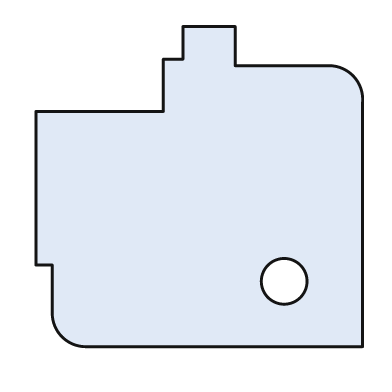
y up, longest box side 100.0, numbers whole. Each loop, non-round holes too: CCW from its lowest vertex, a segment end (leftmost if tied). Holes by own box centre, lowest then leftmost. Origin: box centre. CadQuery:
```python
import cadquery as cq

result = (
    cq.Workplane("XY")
    .moveTo(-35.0, -49.0)
    .lineTo(50.0, -49.0)
    .lineTo(50.0, 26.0)
    .threePointArc((47.0, 34.0), (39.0, 37.0))
    .lineTo(11.0, 37.0)
    .lineTo(11.0, 49.0)
    .lineTo(-5.0, 49.0)
    .lineTo(-5.0, 39.0)
    .lineTo(-11.0, 39.0)
    .lineTo(-11.0, 23.0)
    .lineTo(-50.0, 23.0)
    .lineTo(-50.0, -24.0)
    .lineTo(-45.0, -24.0)
    .lineTo(-45.0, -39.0)
    .threePointArc((-42.0, -46.0), (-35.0, -49.0))
    .close()
    .moveTo(26.0, -29.0)
    .circle(7.0)
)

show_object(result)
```